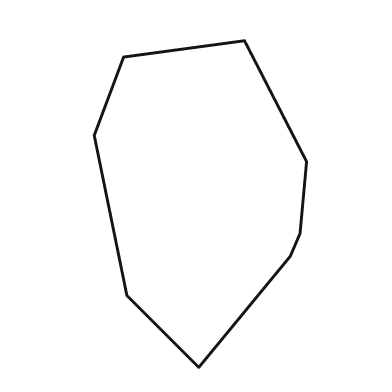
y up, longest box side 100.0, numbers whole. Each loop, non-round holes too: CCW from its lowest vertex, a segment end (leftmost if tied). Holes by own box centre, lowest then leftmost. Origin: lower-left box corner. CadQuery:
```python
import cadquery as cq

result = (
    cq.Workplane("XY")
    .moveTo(32.0, 0.0)
    .lineTo(60.0, 34.0)
    .lineTo(63.0, 41.0)
    .lineTo(65.0, 63.0)
    .lineTo(46.0, 100.0)
    .lineTo(9.0, 95.0)
    .lineTo(0.0, 71.0)
    .lineTo(10.0, 22.0)
    .close()
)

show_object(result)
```